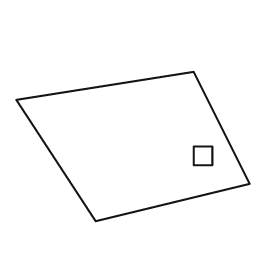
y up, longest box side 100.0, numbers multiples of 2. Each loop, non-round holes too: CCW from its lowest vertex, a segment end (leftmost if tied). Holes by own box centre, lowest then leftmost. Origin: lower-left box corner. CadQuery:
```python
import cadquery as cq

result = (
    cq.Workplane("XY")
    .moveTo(34.0, 0.0)
    .lineTo(100.0, 16.0)
    .lineTo(76.0, 64.0)
    .lineTo(0.0, 52.0)
    .close()
    .moveTo(76.0, 24.0)
    .lineTo(84.0, 24.0)
    .lineTo(84.0, 32.0)
    .lineTo(76.0, 32.0)
    .close()
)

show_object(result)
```